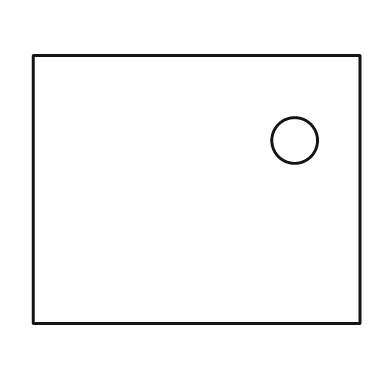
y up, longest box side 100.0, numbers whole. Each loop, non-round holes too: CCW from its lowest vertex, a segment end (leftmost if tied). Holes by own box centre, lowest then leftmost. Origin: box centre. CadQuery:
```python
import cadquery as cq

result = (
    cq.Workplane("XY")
    .moveTo(-50.0, -41.0)
    .lineTo(50.0, -41.0)
    .lineTo(50.0, 41.0)
    .lineTo(-50.0, 41.0)
    .close()
    .moveTo(30.0, 15.0)
    .circle(7.0)
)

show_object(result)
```